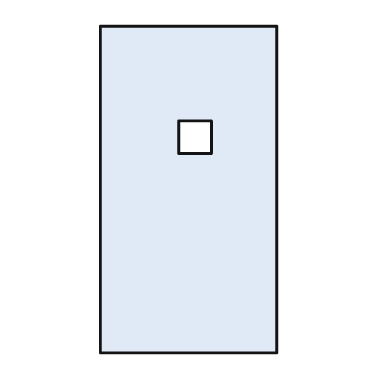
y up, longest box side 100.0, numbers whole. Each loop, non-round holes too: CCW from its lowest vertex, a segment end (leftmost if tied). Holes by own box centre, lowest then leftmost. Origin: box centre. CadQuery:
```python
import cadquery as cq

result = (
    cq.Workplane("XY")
    .moveTo(-27.0, -50.0)
    .lineTo(27.0, -50.0)
    .lineTo(27.0, 50.0)
    .lineTo(-27.0, 50.0)
    .close()
    .moveTo(-3.0, 11.0)
    .lineTo(7.0, 11.0)
    .lineTo(7.0, 21.0)
    .lineTo(-3.0, 21.0)
    .close()
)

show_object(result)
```